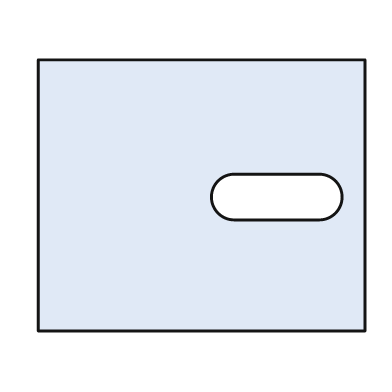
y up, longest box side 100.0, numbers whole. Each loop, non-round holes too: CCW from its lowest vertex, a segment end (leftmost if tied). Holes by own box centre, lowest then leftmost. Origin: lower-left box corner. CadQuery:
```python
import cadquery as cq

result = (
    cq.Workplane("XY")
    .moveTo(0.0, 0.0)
    .lineTo(100.0, 0.0)
    .lineTo(100.0, 83.0)
    .lineTo(0.0, 83.0)
    .close()
    .moveTo(60.0, 34.0)
    .lineTo(86.0, 34.0)
    .threePointArc((93.0, 41.0), (86.0, 48.0))
    .lineTo(60.0, 48.0)
    .threePointArc((53.0, 41.0), (60.0, 34.0))
    .close()
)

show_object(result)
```